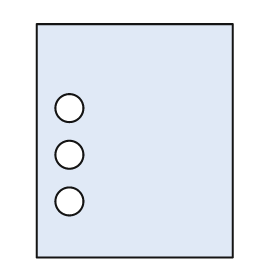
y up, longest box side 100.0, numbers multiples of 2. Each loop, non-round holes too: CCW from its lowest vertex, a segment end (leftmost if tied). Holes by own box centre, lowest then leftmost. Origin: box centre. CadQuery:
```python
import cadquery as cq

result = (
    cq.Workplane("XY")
    .moveTo(-42.0, -50.0)
    .lineTo(42.0, -50.0)
    .lineTo(42.0, 50.0)
    .lineTo(-42.0, 50.0)
    .close()
    .moveTo(-28.0, -26.0)
    .circle(6.0)
    .moveTo(-28.0, -6.0)
    .circle(6.0)
    .moveTo(-28.0, 14.0)
    .circle(6.0)
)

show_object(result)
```